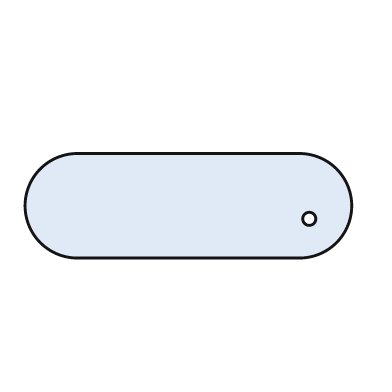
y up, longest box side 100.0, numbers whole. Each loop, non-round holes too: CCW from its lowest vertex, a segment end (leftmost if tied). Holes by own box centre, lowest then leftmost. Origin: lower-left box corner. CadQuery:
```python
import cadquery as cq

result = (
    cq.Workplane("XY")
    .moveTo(16.0, 0.0)
    .lineTo(84.0, 0.0)
    .threePointArc((100.0, 16.0), (84.0, 32.0))
    .lineTo(16.0, 32.0)
    .threePointArc((0.0, 16.0), (16.0, 0.0))
    .close()
    .moveTo(87.0, 12.0)
    .circle(2.0)
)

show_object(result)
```